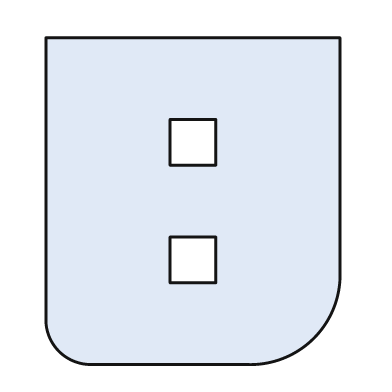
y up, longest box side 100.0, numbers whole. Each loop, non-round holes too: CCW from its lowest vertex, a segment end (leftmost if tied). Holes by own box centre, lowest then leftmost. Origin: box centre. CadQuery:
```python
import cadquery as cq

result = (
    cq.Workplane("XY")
    .moveTo(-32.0, -50.0)
    .lineTo(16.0, -50.0)
    .threePointArc((37.0, -42.0), (45.0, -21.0))
    .lineTo(45.0, 50.0)
    .lineTo(-45.0, 50.0)
    .lineTo(-45.0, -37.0)
    .threePointArc((-41.0, -46.0), (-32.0, -50.0))
    .close()
    .moveTo(-7.0, -25.0)
    .lineTo(7.0, -25.0)
    .lineTo(7.0, -11.0)
    .lineTo(-7.0, -11.0)
    .close()
    .moveTo(-7.0, 11.0)
    .lineTo(7.0, 11.0)
    .lineTo(7.0, 25.0)
    .lineTo(-7.0, 25.0)
    .close()
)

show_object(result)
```